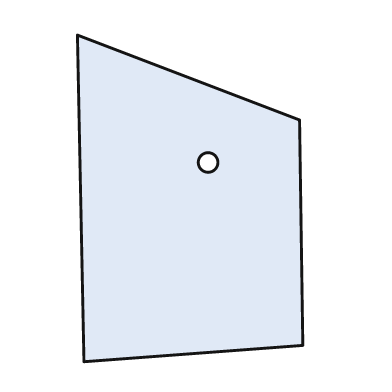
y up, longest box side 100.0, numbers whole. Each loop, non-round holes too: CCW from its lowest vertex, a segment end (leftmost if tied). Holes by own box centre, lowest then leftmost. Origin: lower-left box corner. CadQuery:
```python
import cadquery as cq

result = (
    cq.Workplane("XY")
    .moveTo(2.0, 0.0)
    .lineTo(69.0, 5.0)
    .lineTo(68.0, 74.0)
    .lineTo(0.0, 100.0)
    .close()
    .moveTo(40.0, 61.0)
    .circle(3.0)
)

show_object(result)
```